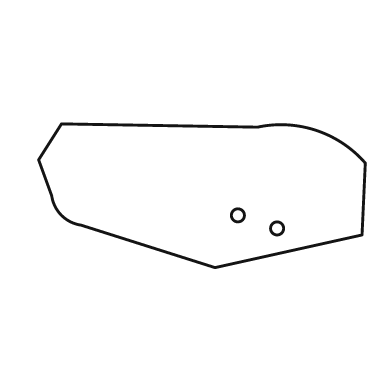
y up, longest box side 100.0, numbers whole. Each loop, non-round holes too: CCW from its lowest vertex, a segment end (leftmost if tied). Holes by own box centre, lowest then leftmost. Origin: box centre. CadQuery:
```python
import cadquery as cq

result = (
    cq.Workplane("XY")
    .moveTo(4.0, -22.0)
    .lineTo(49.0, -12.0)
    .lineTo(50.0, 10.0)
    .threePointArc((35.0, 20.0), (17.0, 21.0))
    .lineTo(-43.0, 22.0)
    .lineTo(-50.0, 11.0)
    .lineTo(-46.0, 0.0)
    .threePointArc((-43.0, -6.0), (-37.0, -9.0))
    .close()
    .moveTo(23.0, -10.0)
    .circle(2.0)
    .moveTo(11.0, -6.0)
    .circle(2.0)
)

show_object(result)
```